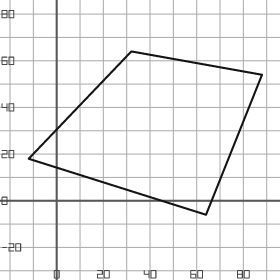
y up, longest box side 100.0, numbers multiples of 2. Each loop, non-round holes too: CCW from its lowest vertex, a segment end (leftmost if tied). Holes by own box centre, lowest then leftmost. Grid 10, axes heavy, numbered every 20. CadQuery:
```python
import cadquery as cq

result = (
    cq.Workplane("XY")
    .moveTo(64.0, -6.0)
    .lineTo(88.0, 54.0)
    .lineTo(32.0, 64.0)
    .lineTo(-12.0, 18.0)
    .close()
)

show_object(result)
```